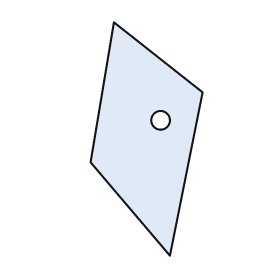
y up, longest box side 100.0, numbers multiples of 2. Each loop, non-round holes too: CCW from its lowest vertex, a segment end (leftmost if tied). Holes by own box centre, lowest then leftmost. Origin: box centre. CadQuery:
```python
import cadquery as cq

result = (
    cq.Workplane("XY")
    .moveTo(10.0, -50.0)
    .lineTo(24.0, 20.0)
    .lineTo(-14.0, 50.0)
    .lineTo(-24.0, -10.0)
    .close()
    .moveTo(6.0, 8.0)
    .circle(4.0)
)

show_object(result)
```